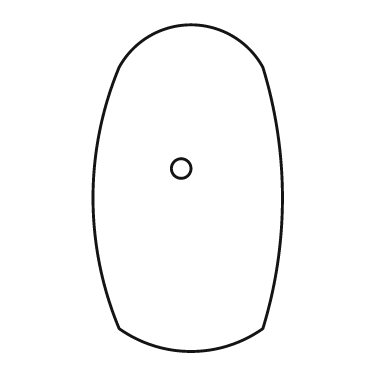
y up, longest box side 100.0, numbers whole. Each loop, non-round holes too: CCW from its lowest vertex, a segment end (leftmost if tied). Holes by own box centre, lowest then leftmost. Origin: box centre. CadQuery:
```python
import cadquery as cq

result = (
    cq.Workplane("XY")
    .moveTo(-21.0, -43.0)
    .threePointArc((1.0, -50.0), (23.0, -43.0))
    .threePointArc((29.0, -3.0), (23.0, 37.0))
    .threePointArc((1.0, 50.0), (-21.0, 37.0))
    .threePointArc((-29.0, -3.0), (-21.0, -43.0))
    .close()
    .moveTo(-2.0, 6.0)
    .circle(3.0)
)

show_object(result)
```